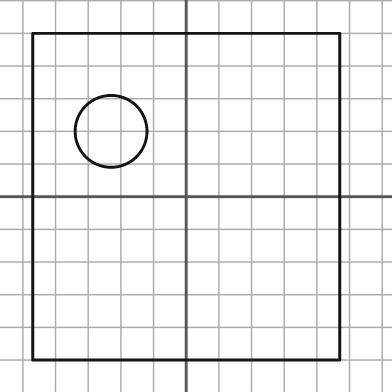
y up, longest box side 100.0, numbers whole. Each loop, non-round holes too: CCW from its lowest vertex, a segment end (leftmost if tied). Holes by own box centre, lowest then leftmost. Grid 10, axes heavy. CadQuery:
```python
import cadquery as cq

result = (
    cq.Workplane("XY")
    .moveTo(-47.0, -50.0)
    .lineTo(47.0, -50.0)
    .lineTo(47.0, 50.0)
    .lineTo(-47.0, 50.0)
    .close()
    .moveTo(-23.0, 20.0)
    .circle(11.0)
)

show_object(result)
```